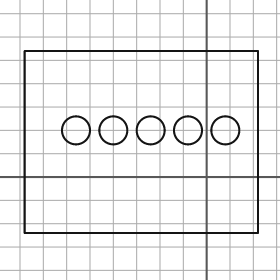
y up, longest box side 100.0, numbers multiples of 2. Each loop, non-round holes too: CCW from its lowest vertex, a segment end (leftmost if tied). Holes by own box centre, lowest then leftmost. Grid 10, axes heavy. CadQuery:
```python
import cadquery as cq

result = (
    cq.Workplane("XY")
    .moveTo(-78.0, -24.0)
    .lineTo(22.0, -24.0)
    .lineTo(22.0, 54.0)
    .lineTo(-78.0, 54.0)
    .close()
    .moveTo(-56.0, 20.0)
    .circle(6.0)
    .moveTo(-40.0, 20.0)
    .circle(6.0)
    .moveTo(-24.0, 20.0)
    .circle(6.0)
    .moveTo(-8.0, 20.0)
    .circle(6.0)
    .moveTo(8.0, 20.0)
    .circle(6.0)
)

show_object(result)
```